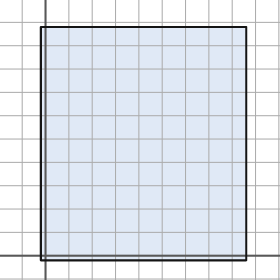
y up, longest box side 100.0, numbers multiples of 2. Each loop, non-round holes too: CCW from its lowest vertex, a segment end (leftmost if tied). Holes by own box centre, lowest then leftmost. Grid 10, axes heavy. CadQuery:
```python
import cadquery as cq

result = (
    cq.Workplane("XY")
    .moveTo(-2.0, -2.0)
    .lineTo(86.0, -2.0)
    .lineTo(86.0, 98.0)
    .lineTo(-2.0, 98.0)
    .close()
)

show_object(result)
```